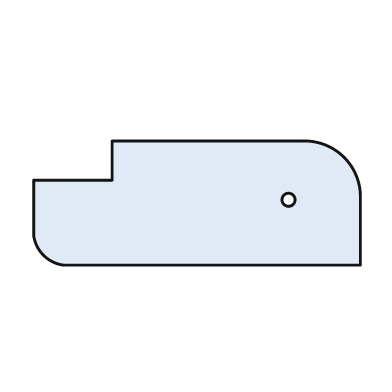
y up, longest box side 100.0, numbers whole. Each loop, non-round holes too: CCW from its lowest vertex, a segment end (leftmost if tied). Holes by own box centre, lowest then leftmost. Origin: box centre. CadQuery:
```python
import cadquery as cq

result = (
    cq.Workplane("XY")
    .moveTo(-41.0, -19.0)
    .lineTo(50.0, -19.0)
    .lineTo(50.0, 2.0)
    .threePointArc((45.0, 14.0), (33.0, 19.0))
    .lineTo(-26.0, 19.0)
    .lineTo(-26.0, 7.0)
    .lineTo(-50.0, 7.0)
    .lineTo(-50.0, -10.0)
    .threePointArc((-47.0, -16.0), (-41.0, -19.0))
    .close()
    .moveTo(28.0, 1.0)
    .circle(2.0)
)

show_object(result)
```